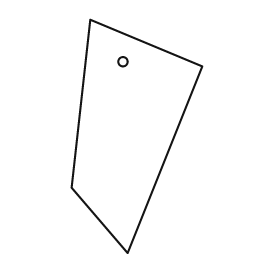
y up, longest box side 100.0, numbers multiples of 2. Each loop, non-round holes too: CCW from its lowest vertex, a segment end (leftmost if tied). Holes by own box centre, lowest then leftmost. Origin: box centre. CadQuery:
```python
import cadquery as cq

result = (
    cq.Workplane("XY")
    .moveTo(-4.0, -50.0)
    .lineTo(28.0, 30.0)
    .lineTo(-20.0, 50.0)
    .lineTo(-28.0, -22.0)
    .close()
    .moveTo(-6.0, 32.0)
    .circle(2.0)
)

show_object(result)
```